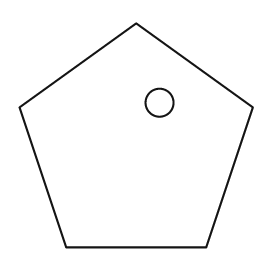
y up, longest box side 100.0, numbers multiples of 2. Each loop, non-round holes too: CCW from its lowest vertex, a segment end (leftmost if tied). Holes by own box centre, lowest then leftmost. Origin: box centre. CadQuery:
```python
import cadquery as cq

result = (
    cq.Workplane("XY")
    .moveTo(-30.0, -48.0)
    .lineTo(30.0, -48.0)
    .lineTo(50.0, 12.0)
    .lineTo(0.0, 48.0)
    .lineTo(-50.0, 12.0)
    .close()
    .moveTo(10.0, 14.0)
    .circle(6.0)
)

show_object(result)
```